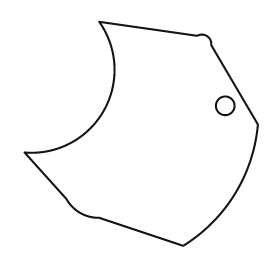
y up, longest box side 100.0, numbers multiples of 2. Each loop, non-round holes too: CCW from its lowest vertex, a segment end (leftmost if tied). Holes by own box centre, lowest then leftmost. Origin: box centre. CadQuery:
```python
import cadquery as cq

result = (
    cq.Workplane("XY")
    .moveTo(18.0, -48.0)
    .threePointArc((40.0, -26.0), (50.0, 4.0))
    .lineTo(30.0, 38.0)
    .threePointArc((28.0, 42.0), (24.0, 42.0))
    .lineTo(-18.0, 48.0)
    .threePointArc((-16.0, 10.0), (-50.0, -8.0))
    .lineTo(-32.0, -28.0)
    .threePointArc((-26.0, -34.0), (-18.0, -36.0))
    .close()
    .moveTo(36.0, 12.0)
    .circle(4.0)
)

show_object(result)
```